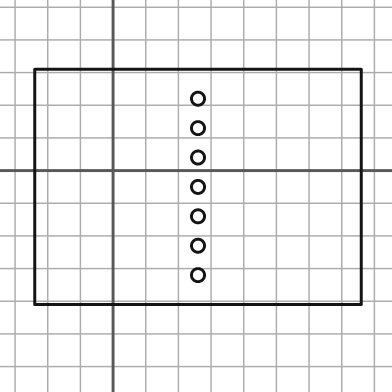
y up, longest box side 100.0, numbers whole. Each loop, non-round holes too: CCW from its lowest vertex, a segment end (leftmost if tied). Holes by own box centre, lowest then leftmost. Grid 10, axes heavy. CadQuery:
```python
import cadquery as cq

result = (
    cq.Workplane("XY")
    .moveTo(-24.0, -41.0)
    .lineTo(76.0, -41.0)
    .lineTo(76.0, 31.0)
    .lineTo(-24.0, 31.0)
    .close()
    .moveTo(26.0, -32.0)
    .circle(2.0)
    .moveTo(26.0, -23.0)
    .circle(2.0)
    .moveTo(26.0, -14.0)
    .circle(2.0)
    .moveTo(26.0, -5.0)
    .circle(2.0)
    .moveTo(26.0, 4.0)
    .circle(2.0)
    .moveTo(26.0, 13.0)
    .circle(2.0)
    .moveTo(26.0, 22.0)
    .circle(2.0)
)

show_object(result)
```